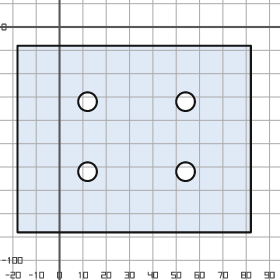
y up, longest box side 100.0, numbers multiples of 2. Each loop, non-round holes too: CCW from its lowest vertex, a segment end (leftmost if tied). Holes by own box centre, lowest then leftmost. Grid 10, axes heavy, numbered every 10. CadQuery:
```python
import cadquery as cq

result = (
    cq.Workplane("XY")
    .moveTo(-18.0, -88.0)
    .lineTo(82.0, -88.0)
    .lineTo(82.0, -8.0)
    .lineTo(-18.0, -8.0)
    .close()
    .moveTo(12.0, -62.0)
    .circle(4.0)
    .moveTo(54.0, -62.0)
    .circle(4.0)
    .moveTo(12.0, -32.0)
    .circle(4.0)
    .moveTo(54.0, -32.0)
    .circle(4.0)
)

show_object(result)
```